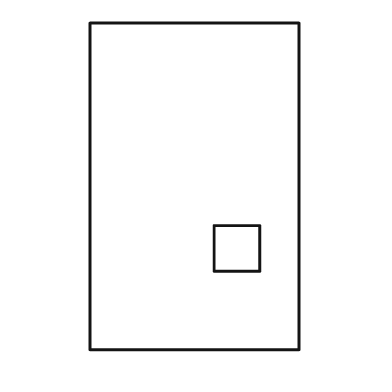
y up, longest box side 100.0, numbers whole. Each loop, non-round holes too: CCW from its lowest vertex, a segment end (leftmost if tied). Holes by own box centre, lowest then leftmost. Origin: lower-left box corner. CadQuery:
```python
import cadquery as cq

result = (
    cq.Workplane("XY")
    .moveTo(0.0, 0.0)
    .lineTo(64.0, 0.0)
    .lineTo(64.0, 100.0)
    .lineTo(0.0, 100.0)
    .close()
    .moveTo(38.0, 24.0)
    .lineTo(52.0, 24.0)
    .lineTo(52.0, 38.0)
    .lineTo(38.0, 38.0)
    .close()
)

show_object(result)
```